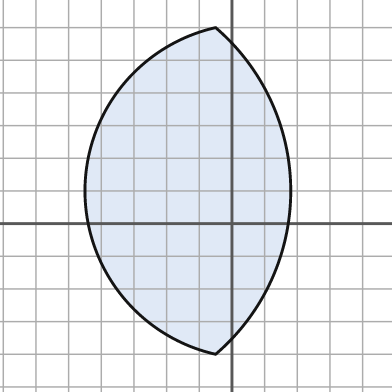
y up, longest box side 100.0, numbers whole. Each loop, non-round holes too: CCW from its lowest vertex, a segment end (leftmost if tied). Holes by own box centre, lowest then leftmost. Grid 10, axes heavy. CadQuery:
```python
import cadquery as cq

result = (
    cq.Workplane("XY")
    .moveTo(-5.0, -40.0)
    .threePointArc((18.0, 10.0), (-5.0, 60.0))
    .threePointArc((-45.0, 10.0), (-5.0, -40.0))
    .close()
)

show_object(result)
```